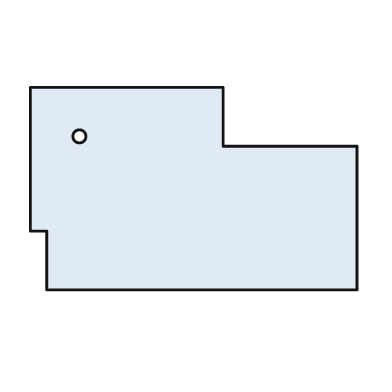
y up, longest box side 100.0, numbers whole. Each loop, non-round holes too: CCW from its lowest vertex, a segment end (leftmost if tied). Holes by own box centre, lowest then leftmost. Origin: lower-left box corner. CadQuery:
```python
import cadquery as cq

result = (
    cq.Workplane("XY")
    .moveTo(5.0, 0.0)
    .lineTo(100.0, 0.0)
    .lineTo(100.0, 44.0)
    .lineTo(59.0, 44.0)
    .lineTo(59.0, 62.0)
    .lineTo(0.0, 62.0)
    .lineTo(0.0, 18.0)
    .lineTo(5.0, 18.0)
    .close()
    .moveTo(15.0, 47.0)
    .circle(2.0)
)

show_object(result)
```